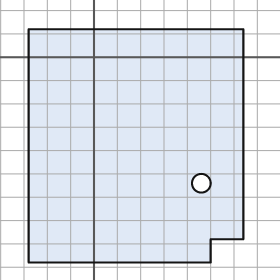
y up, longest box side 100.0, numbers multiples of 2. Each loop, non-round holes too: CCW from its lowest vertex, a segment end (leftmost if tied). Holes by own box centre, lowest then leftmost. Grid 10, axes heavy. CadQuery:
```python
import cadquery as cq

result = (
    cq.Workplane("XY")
    .moveTo(-28.0, -88.0)
    .lineTo(50.0, -88.0)
    .lineTo(50.0, -78.0)
    .lineTo(64.0, -78.0)
    .lineTo(64.0, 12.0)
    .lineTo(-28.0, 12.0)
    .close()
    .moveTo(46.0, -54.0)
    .circle(4.0)
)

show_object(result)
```